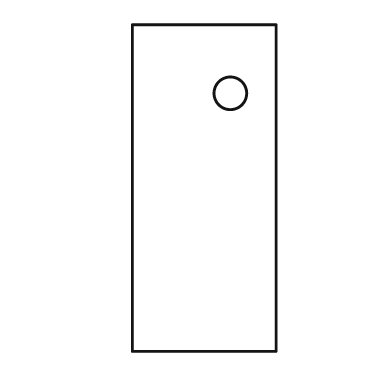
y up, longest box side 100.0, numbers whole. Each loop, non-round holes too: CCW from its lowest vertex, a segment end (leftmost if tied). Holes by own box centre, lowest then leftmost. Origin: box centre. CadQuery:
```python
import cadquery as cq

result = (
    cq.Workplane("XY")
    .moveTo(-22.0, -50.0)
    .lineTo(22.0, -50.0)
    .lineTo(22.0, 50.0)
    .lineTo(-22.0, 50.0)
    .close()
    .moveTo(8.0, 29.0)
    .circle(5.0)
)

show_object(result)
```